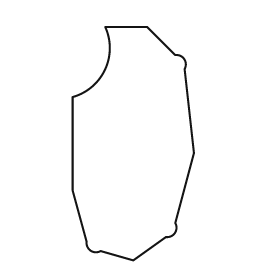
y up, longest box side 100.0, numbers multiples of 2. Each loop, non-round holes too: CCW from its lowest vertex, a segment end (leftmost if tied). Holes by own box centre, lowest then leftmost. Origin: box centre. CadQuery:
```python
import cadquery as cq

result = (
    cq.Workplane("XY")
    .moveTo(0.0, -50.0)
    .lineTo(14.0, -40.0)
    .threePointArc((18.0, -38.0), (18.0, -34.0))
    .lineTo(26.0, -4.0)
    .lineTo(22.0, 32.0)
    .threePointArc((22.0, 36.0), (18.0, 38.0))
    .lineTo(6.0, 50.0)
    .lineTo(-12.0, 50.0)
    .threePointArc((-12.0, 32.0), (-26.0, 20.0))
    .lineTo(-26.0, -20.0)
    .lineTo(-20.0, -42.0)
    .threePointArc((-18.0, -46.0), (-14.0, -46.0))
    .close()
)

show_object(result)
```